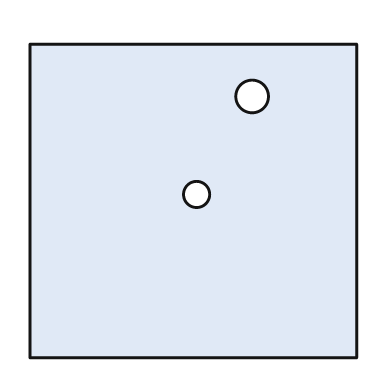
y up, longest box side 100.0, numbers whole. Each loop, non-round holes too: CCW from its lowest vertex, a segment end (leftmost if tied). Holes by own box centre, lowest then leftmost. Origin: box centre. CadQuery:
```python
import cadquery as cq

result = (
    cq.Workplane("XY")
    .moveTo(-50.0, -48.0)
    .lineTo(50.0, -48.0)
    .lineTo(50.0, 48.0)
    .lineTo(-50.0, 48.0)
    .close()
    .moveTo(1.0, 2.0)
    .circle(4.0)
    .moveTo(18.0, 32.0)
    .circle(5.0)
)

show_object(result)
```